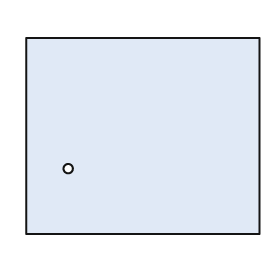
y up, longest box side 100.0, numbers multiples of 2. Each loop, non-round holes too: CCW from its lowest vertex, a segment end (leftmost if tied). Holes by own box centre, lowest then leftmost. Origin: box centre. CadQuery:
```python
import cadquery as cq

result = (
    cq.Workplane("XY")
    .moveTo(-50.0, -42.0)
    .lineTo(50.0, -42.0)
    .lineTo(50.0, 42.0)
    .lineTo(-50.0, 42.0)
    .close()
    .moveTo(-32.0, -14.0)
    .circle(2.0)
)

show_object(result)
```